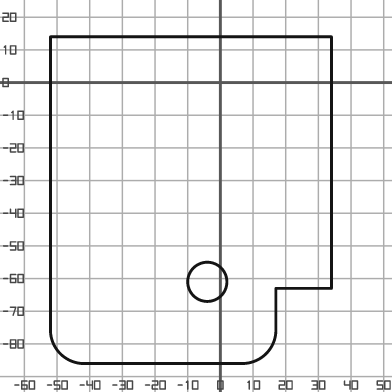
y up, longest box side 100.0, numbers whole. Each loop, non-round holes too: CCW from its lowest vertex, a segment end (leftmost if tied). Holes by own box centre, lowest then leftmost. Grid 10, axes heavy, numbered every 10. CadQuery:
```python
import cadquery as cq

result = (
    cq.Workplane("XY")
    .moveTo(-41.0, -86.0)
    .lineTo(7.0, -86.0)
    .threePointArc((14.0, -83.0), (17.0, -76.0))
    .lineTo(17.0, -63.0)
    .lineTo(34.0, -63.0)
    .lineTo(34.0, 14.0)
    .lineTo(-52.0, 14.0)
    .lineTo(-52.0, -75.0)
    .threePointArc((-49.0, -83.0), (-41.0, -86.0))
    .close()
    .moveTo(-4.0, -61.0)
    .circle(6.0)
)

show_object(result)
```